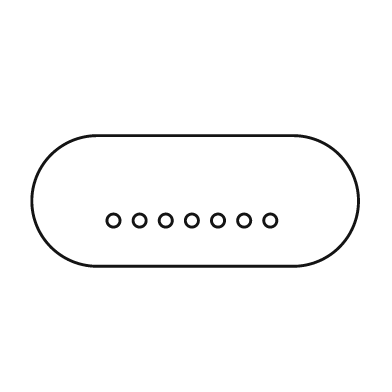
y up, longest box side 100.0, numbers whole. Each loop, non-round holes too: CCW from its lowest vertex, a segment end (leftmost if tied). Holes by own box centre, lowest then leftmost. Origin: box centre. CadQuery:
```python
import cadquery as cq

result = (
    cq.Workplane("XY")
    .moveTo(-30.0, -20.0)
    .lineTo(30.0, -20.0)
    .threePointArc((50.0, 0.0), (30.0, 20.0))
    .lineTo(-30.0, 20.0)
    .threePointArc((-50.0, 0.0), (-30.0, -20.0))
    .close()
    .moveTo(-25.0, -6.0)
    .circle(2.0)
    .moveTo(-17.0, -6.0)
    .circle(2.0)
    .moveTo(-9.0, -6.0)
    .circle(2.0)
    .moveTo(-1.0, -6.0)
    .circle(2.0)
    .moveTo(7.0, -6.0)
    .circle(2.0)
    .moveTo(15.0, -6.0)
    .circle(2.0)
    .moveTo(23.0, -6.0)
    .circle(2.0)
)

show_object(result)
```